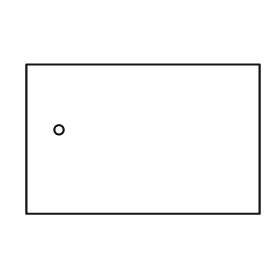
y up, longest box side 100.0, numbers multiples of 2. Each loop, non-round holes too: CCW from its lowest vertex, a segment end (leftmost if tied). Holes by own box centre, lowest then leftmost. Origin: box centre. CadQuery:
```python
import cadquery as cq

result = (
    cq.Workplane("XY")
    .moveTo(-50.0, -32.0)
    .lineTo(50.0, -32.0)
    .lineTo(50.0, 32.0)
    .lineTo(-50.0, 32.0)
    .close()
    .moveTo(-36.0, 4.0)
    .circle(2.0)
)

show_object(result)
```